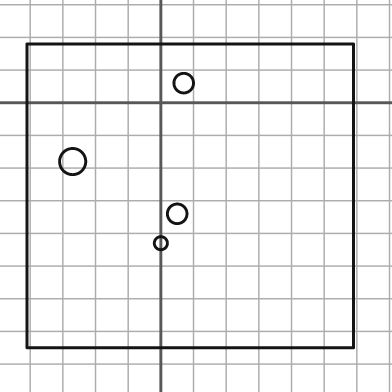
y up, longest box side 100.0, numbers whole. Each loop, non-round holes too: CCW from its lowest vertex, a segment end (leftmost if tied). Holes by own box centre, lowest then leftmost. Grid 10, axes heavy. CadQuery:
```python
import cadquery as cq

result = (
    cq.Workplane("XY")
    .moveTo(-41.0, -75.0)
    .lineTo(59.0, -75.0)
    .lineTo(59.0, 18.0)
    .lineTo(-41.0, 18.0)
    .close()
    .moveTo(0.0, -43.0)
    .circle(2.0)
    .moveTo(5.0, -34.0)
    .circle(3.0)
    .moveTo(-27.0, -18.0)
    .circle(4.0)
    .moveTo(7.0, 6.0)
    .circle(3.0)
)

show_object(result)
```